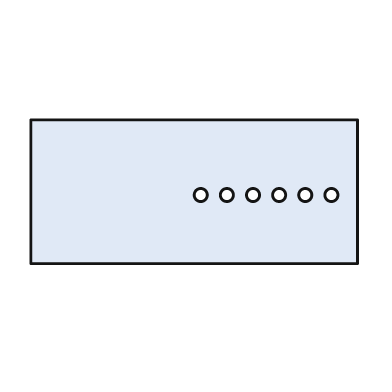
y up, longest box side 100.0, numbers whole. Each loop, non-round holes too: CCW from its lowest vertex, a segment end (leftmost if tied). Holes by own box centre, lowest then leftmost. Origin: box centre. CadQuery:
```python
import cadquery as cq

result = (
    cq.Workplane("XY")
    .moveTo(-50.0, -22.0)
    .lineTo(50.0, -22.0)
    .lineTo(50.0, 22.0)
    .lineTo(-50.0, 22.0)
    .close()
    .moveTo(2.0, -1.0)
    .circle(2.0)
    .moveTo(10.0, -1.0)
    .circle(2.0)
    .moveTo(18.0, -1.0)
    .circle(2.0)
    .moveTo(26.0, -1.0)
    .circle(2.0)
    .moveTo(34.0, -1.0)
    .circle(2.0)
    .moveTo(42.0, -1.0)
    .circle(2.0)
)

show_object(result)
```